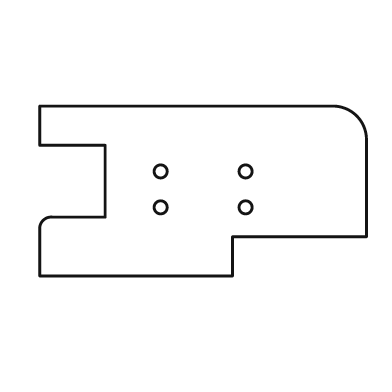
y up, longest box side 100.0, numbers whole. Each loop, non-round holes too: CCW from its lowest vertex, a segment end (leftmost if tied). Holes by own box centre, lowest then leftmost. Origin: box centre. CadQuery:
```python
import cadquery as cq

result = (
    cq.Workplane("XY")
    .moveTo(-50.0, -26.0)
    .lineTo(9.0, -26.0)
    .lineTo(9.0, -14.0)
    .lineTo(50.0, -14.0)
    .lineTo(50.0, 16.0)
    .threePointArc((47.0, 23.0), (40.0, 26.0))
    .lineTo(-50.0, 26.0)
    .lineTo(-50.0, 14.0)
    .lineTo(-30.0, 14.0)
    .lineTo(-30.0, -8.0)
    .lineTo(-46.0, -8.0)
    .threePointArc((-49.0, -9.0), (-50.0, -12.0))
    .close()
    .moveTo(-13.0, -5.0)
    .circle(2.0)
    .moveTo(13.0, -5.0)
    .circle(2.0)
    .moveTo(-13.0, 6.0)
    .circle(2.0)
    .moveTo(13.0, 6.0)
    .circle(2.0)
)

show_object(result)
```